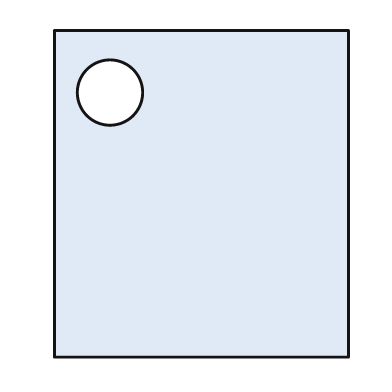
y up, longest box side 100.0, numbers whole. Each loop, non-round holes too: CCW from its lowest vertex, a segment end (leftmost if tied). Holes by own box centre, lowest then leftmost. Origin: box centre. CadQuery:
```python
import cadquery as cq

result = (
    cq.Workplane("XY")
    .moveTo(-45.0, -50.0)
    .lineTo(45.0, -50.0)
    .lineTo(45.0, 50.0)
    .lineTo(-45.0, 50.0)
    .close()
    .moveTo(-28.0, 31.0)
    .circle(10.0)
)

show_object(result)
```